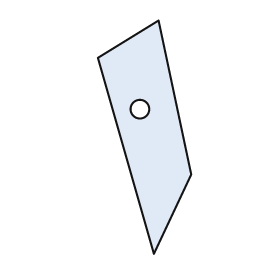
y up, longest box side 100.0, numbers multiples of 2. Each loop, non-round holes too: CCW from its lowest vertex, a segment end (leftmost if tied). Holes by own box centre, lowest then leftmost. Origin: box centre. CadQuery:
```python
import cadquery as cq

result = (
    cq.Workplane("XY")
    .moveTo(4.0, -50.0)
    .lineTo(20.0, -16.0)
    .lineTo(6.0, 50.0)
    .lineTo(-20.0, 34.0)
    .close()
    .moveTo(-2.0, 12.0)
    .circle(4.0)
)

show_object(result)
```